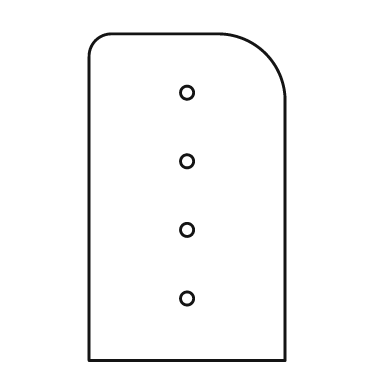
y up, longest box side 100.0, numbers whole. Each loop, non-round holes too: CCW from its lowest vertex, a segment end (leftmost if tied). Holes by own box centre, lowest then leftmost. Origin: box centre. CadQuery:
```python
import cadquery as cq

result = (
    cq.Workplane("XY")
    .moveTo(-30.0, -50.0)
    .lineTo(30.0, -50.0)
    .lineTo(30.0, 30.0)
    .threePointArc((24.0, 44.0), (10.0, 50.0))
    .lineTo(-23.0, 50.0)
    .threePointArc((-28.0, 48.0), (-30.0, 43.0))
    .close()
    .moveTo(0.0, -31.0)
    .circle(2.0)
    .moveTo(0.0, -10.0)
    .circle(2.0)
    .moveTo(0.0, 11.0)
    .circle(2.0)
    .moveTo(0.0, 32.0)
    .circle(2.0)
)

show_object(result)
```